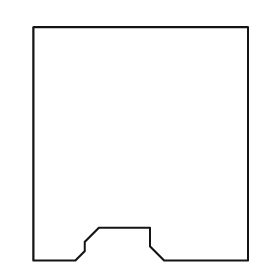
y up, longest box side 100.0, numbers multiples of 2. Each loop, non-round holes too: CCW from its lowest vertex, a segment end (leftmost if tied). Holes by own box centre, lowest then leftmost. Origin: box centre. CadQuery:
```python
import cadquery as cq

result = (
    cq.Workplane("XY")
    .moveTo(-46.0, -50.0)
    .lineTo(-28.0, -50.0)
    .lineTo(-24.0, -46.0)
    .lineTo(-24.0, -42.0)
    .lineTo(-18.0, -36.0)
    .lineTo(4.0, -36.0)
    .lineTo(4.0, -44.0)
    .lineTo(10.0, -50.0)
    .lineTo(46.0, -50.0)
    .lineTo(46.0, 50.0)
    .lineTo(-46.0, 50.0)
    .close()
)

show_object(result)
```